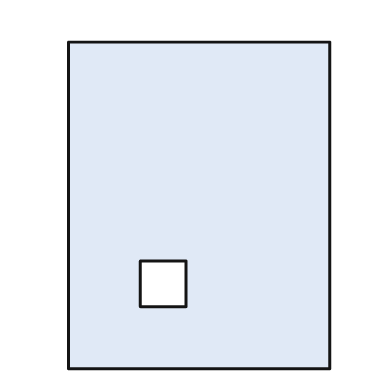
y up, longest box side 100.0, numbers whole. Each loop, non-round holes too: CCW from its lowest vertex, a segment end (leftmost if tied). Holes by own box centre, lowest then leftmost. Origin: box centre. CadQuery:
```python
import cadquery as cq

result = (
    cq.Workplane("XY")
    .moveTo(-40.0, -50.0)
    .lineTo(40.0, -50.0)
    .lineTo(40.0, 50.0)
    .lineTo(-40.0, 50.0)
    .close()
    .moveTo(-18.0, -31.0)
    .lineTo(-4.0, -31.0)
    .lineTo(-4.0, -17.0)
    .lineTo(-18.0, -17.0)
    .close()
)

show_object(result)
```